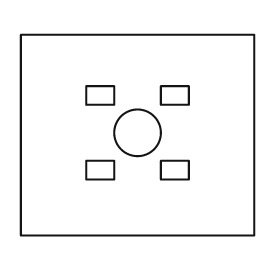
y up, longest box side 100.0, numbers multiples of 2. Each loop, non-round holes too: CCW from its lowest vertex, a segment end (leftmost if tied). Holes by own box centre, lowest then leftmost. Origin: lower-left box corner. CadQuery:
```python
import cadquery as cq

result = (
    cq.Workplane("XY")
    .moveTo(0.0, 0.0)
    .lineTo(100.0, 0.0)
    .lineTo(100.0, 86.0)
    .lineTo(0.0, 86.0)
    .close()
    .moveTo(28.0, 24.0)
    .lineTo(40.0, 24.0)
    .lineTo(40.0, 32.0)
    .lineTo(28.0, 32.0)
    .close()
    .moveTo(60.0, 24.0)
    .lineTo(72.0, 24.0)
    .lineTo(72.0, 32.0)
    .lineTo(60.0, 32.0)
    .close()
    .moveTo(50.0, 44.0)
    .circle(10.0)
    .moveTo(28.0, 56.0)
    .lineTo(40.0, 56.0)
    .lineTo(40.0, 64.0)
    .lineTo(28.0, 64.0)
    .close()
    .moveTo(60.0, 56.0)
    .lineTo(72.0, 56.0)
    .lineTo(72.0, 64.0)
    .lineTo(60.0, 64.0)
    .close()
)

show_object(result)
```